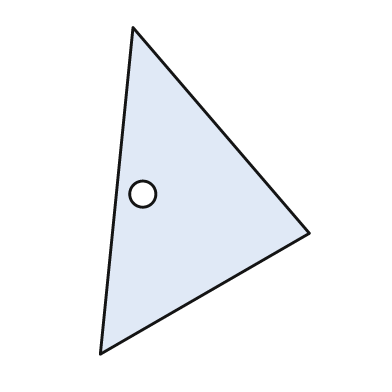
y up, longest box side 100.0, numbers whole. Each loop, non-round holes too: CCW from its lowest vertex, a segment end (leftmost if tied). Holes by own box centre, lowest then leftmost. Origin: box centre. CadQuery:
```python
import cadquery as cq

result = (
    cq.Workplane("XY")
    .moveTo(-32.0, -50.0)
    .lineTo(32.0, -13.0)
    .lineTo(-22.0, 50.0)
    .close()
    .moveTo(-19.0, -1.0)
    .circle(4.0)
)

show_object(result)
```